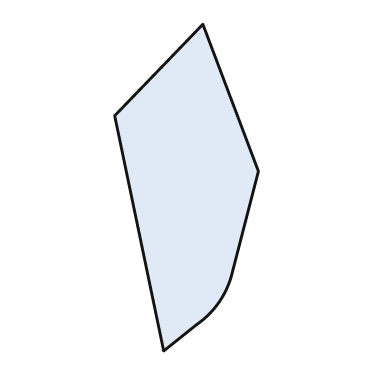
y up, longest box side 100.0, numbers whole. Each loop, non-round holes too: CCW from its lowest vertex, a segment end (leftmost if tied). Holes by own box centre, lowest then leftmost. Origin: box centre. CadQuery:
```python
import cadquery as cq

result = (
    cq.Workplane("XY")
    .moveTo(-7.0, -50.0)
    .lineTo(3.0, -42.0)
    .threePointArc((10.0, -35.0), (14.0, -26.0))
    .lineTo(22.0, 5.0)
    .lineTo(5.0, 50.0)
    .lineTo(-22.0, 22.0)
    .close()
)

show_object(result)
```